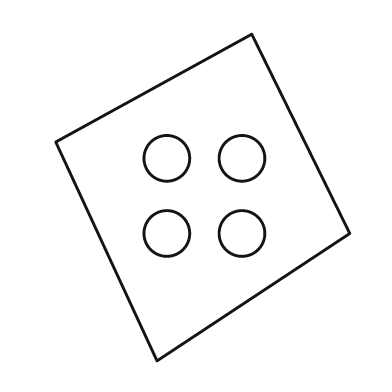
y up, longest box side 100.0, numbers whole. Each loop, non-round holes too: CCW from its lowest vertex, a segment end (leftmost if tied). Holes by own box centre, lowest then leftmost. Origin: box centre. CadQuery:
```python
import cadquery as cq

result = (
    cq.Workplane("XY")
    .moveTo(-14.0, -50.0)
    .lineTo(45.0, -11.0)
    .lineTo(15.0, 50.0)
    .lineTo(-45.0, 17.0)
    .close()
    .moveTo(-11.0, -11.0)
    .circle(7.0)
    .moveTo(12.0, -11.0)
    .circle(7.0)
    .moveTo(-11.0, 12.0)
    .circle(7.0)
    .moveTo(12.0, 12.0)
    .circle(7.0)
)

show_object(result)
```